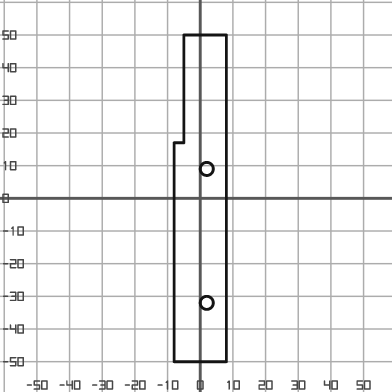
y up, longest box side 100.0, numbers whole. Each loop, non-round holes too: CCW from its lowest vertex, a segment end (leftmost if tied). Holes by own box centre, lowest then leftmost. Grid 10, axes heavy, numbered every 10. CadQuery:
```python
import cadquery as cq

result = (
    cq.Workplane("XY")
    .moveTo(-8.0, -50.0)
    .lineTo(8.0, -50.0)
    .lineTo(8.0, 50.0)
    .lineTo(-5.0, 50.0)
    .lineTo(-5.0, 17.0)
    .lineTo(-8.0, 17.0)
    .close()
    .moveTo(2.0, -32.0)
    .circle(2.0)
    .moveTo(2.0, 9.0)
    .circle(2.0)
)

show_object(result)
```